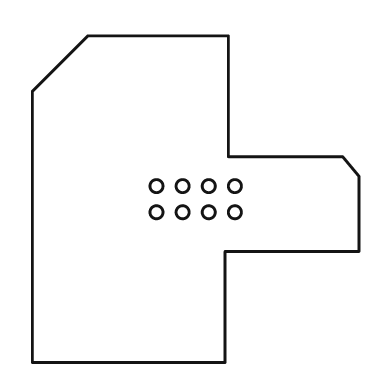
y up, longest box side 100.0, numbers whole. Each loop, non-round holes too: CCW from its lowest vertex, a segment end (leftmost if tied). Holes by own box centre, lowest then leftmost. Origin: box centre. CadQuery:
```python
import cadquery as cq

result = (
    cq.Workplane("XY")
    .moveTo(-50.0, -50.0)
    .lineTo(9.0, -50.0)
    .lineTo(9.0, -16.0)
    .lineTo(50.0, -16.0)
    .lineTo(50.0, 7.0)
    .lineTo(45.0, 13.0)
    .lineTo(10.0, 13.0)
    .lineTo(10.0, 50.0)
    .lineTo(-33.0, 50.0)
    .lineTo(-50.0, 33.0)
    .close()
    .moveTo(-12.0, -4.0)
    .circle(2.0)
    .moveTo(-4.0, -4.0)
    .circle(2.0)
    .moveTo(4.0, -4.0)
    .circle(2.0)
    .moveTo(12.0, -4.0)
    .circle(2.0)
    .moveTo(-12.0, 4.0)
    .circle(2.0)
    .moveTo(-4.0, 4.0)
    .circle(2.0)
    .moveTo(4.0, 4.0)
    .circle(2.0)
    .moveTo(12.0, 4.0)
    .circle(2.0)
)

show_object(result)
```